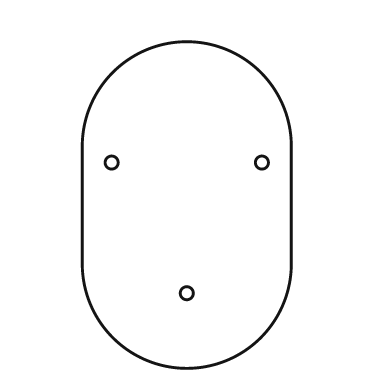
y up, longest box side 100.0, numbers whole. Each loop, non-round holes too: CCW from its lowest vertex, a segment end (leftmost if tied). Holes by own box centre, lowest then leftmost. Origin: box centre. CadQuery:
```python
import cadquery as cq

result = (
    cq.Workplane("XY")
    .moveTo(-32.0, -18.0)
    .threePointArc((0.0, -50.0), (32.0, -18.0))
    .lineTo(32.0, 18.0)
    .threePointArc((0.0, 50.0), (-32.0, 18.0))
    .close()
    .moveTo(0.0, -27.0)
    .circle(2.0)
    .moveTo(-23.0, 13.0)
    .circle(2.0)
    .moveTo(23.0, 13.0)
    .circle(2.0)
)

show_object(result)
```